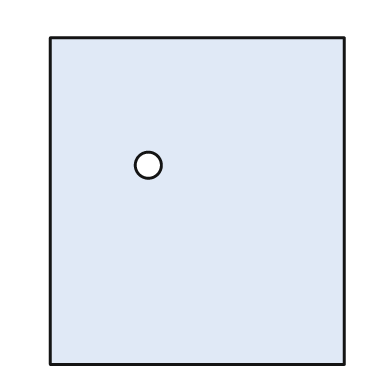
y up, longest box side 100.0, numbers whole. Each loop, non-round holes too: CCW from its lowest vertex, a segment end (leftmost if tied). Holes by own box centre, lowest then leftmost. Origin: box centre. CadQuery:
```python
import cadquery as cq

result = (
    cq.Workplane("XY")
    .moveTo(-45.0, -50.0)
    .lineTo(45.0, -50.0)
    .lineTo(45.0, 50.0)
    .lineTo(-45.0, 50.0)
    .close()
    .moveTo(-15.0, 11.0)
    .circle(4.0)
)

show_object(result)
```